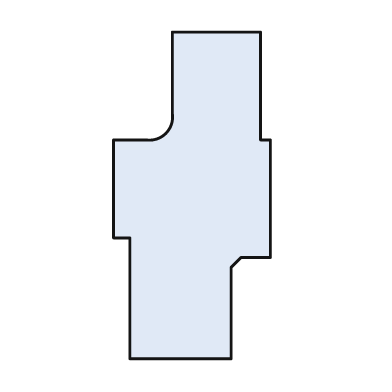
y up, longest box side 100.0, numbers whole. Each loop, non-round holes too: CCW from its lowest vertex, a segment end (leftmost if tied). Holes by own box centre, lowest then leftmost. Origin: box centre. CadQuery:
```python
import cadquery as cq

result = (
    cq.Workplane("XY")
    .moveTo(-19.0, -50.0)
    .lineTo(12.0, -50.0)
    .lineTo(12.0, -22.0)
    .lineTo(15.0, -19.0)
    .lineTo(24.0, -19.0)
    .lineTo(24.0, 17.0)
    .lineTo(21.0, 17.0)
    .lineTo(21.0, 50.0)
    .lineTo(-6.0, 50.0)
    .lineTo(-6.0, 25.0)
    .threePointArc((-8.0, 19.0), (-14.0, 17.0))
    .lineTo(-24.0, 17.0)
    .lineTo(-24.0, -13.0)
    .lineTo(-19.0, -13.0)
    .close()
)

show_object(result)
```